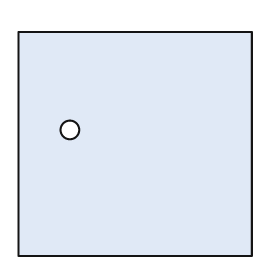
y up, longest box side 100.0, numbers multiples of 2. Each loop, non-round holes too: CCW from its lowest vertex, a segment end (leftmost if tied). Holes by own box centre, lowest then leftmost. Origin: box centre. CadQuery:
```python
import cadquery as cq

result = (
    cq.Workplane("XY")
    .moveTo(-50.0, -48.0)
    .lineTo(50.0, -48.0)
    .lineTo(50.0, 48.0)
    .lineTo(-50.0, 48.0)
    .close()
    .moveTo(-28.0, 6.0)
    .circle(4.0)
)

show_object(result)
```